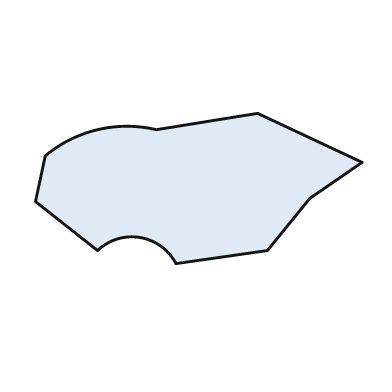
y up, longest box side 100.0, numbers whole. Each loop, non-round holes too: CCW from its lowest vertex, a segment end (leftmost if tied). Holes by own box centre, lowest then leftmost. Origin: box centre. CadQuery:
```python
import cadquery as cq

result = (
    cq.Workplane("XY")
    .moveTo(-7.0, -23.0)
    .lineTo(21.0, -19.0)
    .lineTo(34.0, -3.0)
    .lineTo(50.0, 8.0)
    .lineTo(18.0, 23.0)
    .lineTo(-13.0, 18.0)
    .threePointArc((-31.0, 18.0), (-47.0, 10.0))
    .lineTo(-50.0, -4.0)
    .lineTo(-31.0, -19.0)
    .threePointArc((-18.0, -15.0), (-7.0, -23.0))
    .close()
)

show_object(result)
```